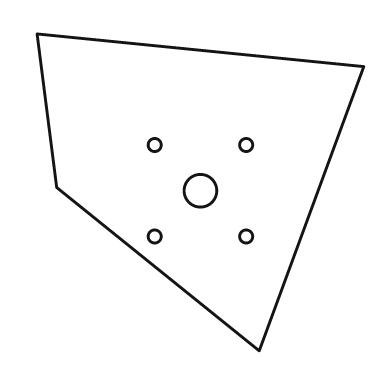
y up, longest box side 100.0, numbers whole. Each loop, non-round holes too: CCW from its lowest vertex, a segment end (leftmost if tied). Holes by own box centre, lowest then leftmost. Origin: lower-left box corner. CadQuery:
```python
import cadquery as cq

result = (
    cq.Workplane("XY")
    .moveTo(68.0, 0.0)
    .lineTo(100.0, 87.0)
    .lineTo(0.0, 97.0)
    .lineTo(6.0, 50.0)
    .close()
    .moveTo(36.0, 35.0)
    .circle(2.0)
    .moveTo(64.0, 35.0)
    .circle(2.0)
    .moveTo(50.0, 49.0)
    .circle(5.0)
    .moveTo(36.0, 63.0)
    .circle(2.0)
    .moveTo(64.0, 63.0)
    .circle(2.0)
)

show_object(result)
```